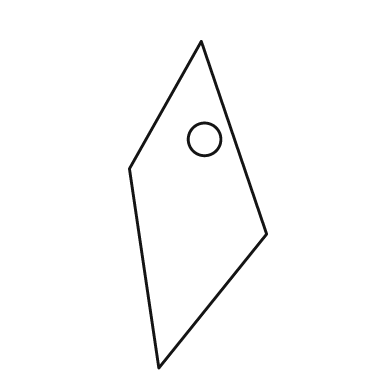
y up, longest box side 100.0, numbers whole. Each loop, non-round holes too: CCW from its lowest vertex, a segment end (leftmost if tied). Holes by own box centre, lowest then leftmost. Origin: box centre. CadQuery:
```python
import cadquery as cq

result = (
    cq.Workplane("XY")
    .moveTo(-12.0, -50.0)
    .lineTo(21.0, -9.0)
    .lineTo(1.0, 50.0)
    .lineTo(-21.0, 11.0)
    .close()
    .moveTo(2.0, 20.0)
    .circle(5.0)
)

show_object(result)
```